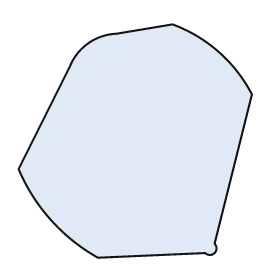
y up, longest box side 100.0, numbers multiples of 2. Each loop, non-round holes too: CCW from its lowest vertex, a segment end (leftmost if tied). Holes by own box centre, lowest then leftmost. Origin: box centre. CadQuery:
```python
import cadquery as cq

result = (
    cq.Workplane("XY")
    .moveTo(-16.0, -50.0)
    .lineTo(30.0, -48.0)
    .threePointArc((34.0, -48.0), (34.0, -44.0))
    .lineTo(50.0, 20.0)
    .threePointArc((36.0, 38.0), (16.0, 50.0))
    .lineTo(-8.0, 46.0)
    .threePointArc((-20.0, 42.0), (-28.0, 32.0))
    .lineTo(-50.0, -12.0)
    .threePointArc((-36.0, -34.0), (-16.0, -50.0))
    .close()
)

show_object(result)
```